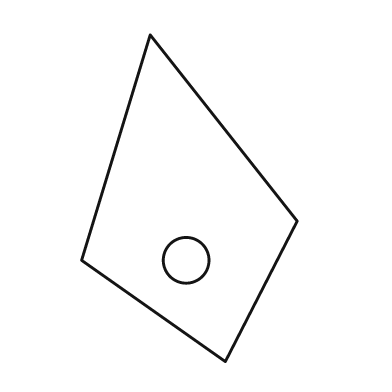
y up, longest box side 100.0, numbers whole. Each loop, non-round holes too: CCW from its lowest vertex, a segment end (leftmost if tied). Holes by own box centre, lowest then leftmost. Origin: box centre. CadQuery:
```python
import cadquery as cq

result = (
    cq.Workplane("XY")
    .moveTo(11.0, -50.0)
    .lineTo(33.0, -7.0)
    .lineTo(-12.0, 50.0)
    .lineTo(-33.0, -19.0)
    .close()
    .moveTo(-1.0, -19.0)
    .circle(7.0)
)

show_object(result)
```